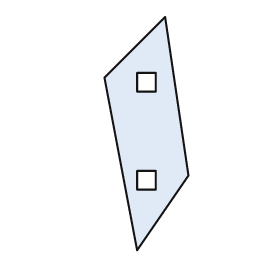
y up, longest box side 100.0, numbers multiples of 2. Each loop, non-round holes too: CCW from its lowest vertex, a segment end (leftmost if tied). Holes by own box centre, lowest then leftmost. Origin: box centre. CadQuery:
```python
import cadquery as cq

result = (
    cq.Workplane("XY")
    .moveTo(-4.0, -50.0)
    .lineTo(18.0, -18.0)
    .lineTo(8.0, 50.0)
    .lineTo(-18.0, 24.0)
    .close()
    .moveTo(-4.0, -24.0)
    .lineTo(4.0, -24.0)
    .lineTo(4.0, -16.0)
    .lineTo(-4.0, -16.0)
    .close()
    .moveTo(-4.0, 18.0)
    .lineTo(4.0, 18.0)
    .lineTo(4.0, 26.0)
    .lineTo(-4.0, 26.0)
    .close()
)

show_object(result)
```